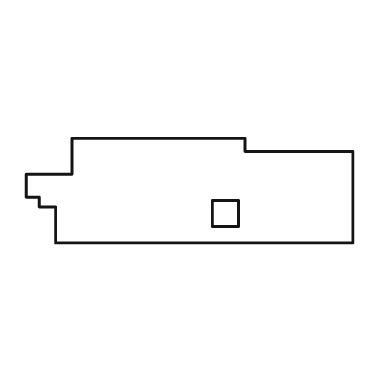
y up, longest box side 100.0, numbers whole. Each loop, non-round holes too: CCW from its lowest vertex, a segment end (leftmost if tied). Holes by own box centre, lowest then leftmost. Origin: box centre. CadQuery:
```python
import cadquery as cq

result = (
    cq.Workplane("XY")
    .moveTo(-41.0, -16.0)
    .lineTo(50.0, -16.0)
    .lineTo(50.0, 12.0)
    .lineTo(17.0, 12.0)
    .lineTo(17.0, 16.0)
    .lineTo(-36.0, 16.0)
    .lineTo(-36.0, 5.0)
    .lineTo(-50.0, 5.0)
    .lineTo(-50.0, -2.0)
    .lineTo(-46.0, -2.0)
    .lineTo(-46.0, -5.0)
    .lineTo(-41.0, -5.0)
    .close()
    .moveTo(7.0, -11.0)
    .lineTo(15.0, -11.0)
    .lineTo(15.0, -3.0)
    .lineTo(7.0, -3.0)
    .close()
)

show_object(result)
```